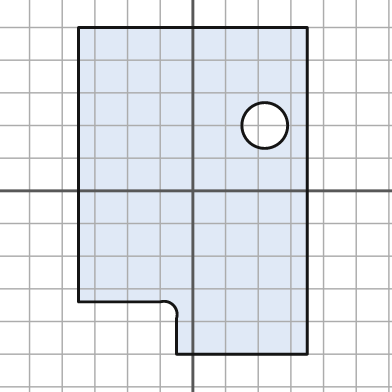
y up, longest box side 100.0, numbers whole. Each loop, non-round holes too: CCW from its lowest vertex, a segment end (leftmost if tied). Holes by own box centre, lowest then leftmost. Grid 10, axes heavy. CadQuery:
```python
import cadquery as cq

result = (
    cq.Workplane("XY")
    .moveTo(-5.0, -50.0)
    .lineTo(35.0, -50.0)
    .lineTo(35.0, 50.0)
    .lineTo(-35.0, 50.0)
    .lineTo(-35.0, -34.0)
    .lineTo(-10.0, -34.0)
    .threePointArc((-6.0, -35.0), (-5.0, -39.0))
    .close()
    .moveTo(22.0, 20.0)
    .circle(7.0)
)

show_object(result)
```